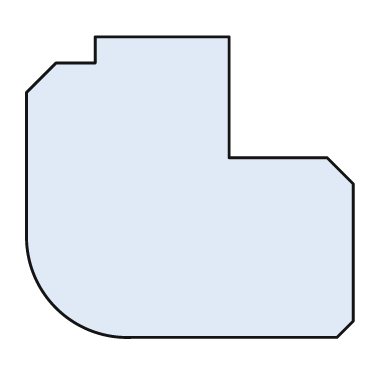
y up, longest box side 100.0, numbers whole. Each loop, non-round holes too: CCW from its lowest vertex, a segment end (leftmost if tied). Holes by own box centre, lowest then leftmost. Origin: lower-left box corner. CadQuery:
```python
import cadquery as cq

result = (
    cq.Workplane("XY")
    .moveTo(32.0, 0.0)
    .lineTo(95.0, 0.0)
    .lineTo(100.0, 5.0)
    .lineTo(100.0, 47.0)
    .lineTo(92.0, 55.0)
    .lineTo(62.0, 55.0)
    .lineTo(62.0, 92.0)
    .lineTo(21.0, 92.0)
    .lineTo(21.0, 84.0)
    .lineTo(9.0, 84.0)
    .lineTo(0.0, 75.0)
    .lineTo(0.0, 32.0)
    .threePointArc((9.0, 9.0), (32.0, 0.0))
    .close()
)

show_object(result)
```